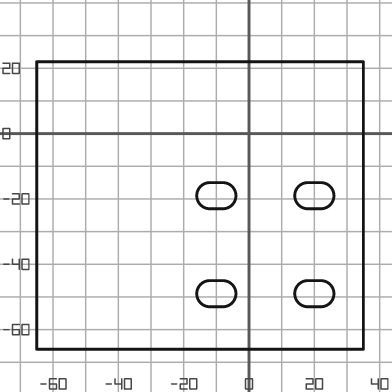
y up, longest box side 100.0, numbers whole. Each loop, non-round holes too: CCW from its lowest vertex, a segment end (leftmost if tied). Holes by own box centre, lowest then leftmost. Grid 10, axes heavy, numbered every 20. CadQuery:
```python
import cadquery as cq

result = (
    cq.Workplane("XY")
    .moveTo(-65.0, -66.0)
    .lineTo(35.0, -66.0)
    .lineTo(35.0, 22.0)
    .lineTo(-65.0, 22.0)
    .close()
    .moveTo(-12.0, -53.0)
    .lineTo(-8.0, -53.0)
    .threePointArc((-4.0, -49.0), (-8.0, -45.0))
    .lineTo(-12.0, -45.0)
    .threePointArc((-16.0, -49.0), (-12.0, -53.0))
    .close()
    .moveTo(18.0, -53.0)
    .lineTo(22.0, -53.0)
    .threePointArc((26.0, -49.0), (22.0, -45.0))
    .lineTo(18.0, -45.0)
    .threePointArc((14.0, -49.0), (18.0, -53.0))
    .close()
    .moveTo(-12.0, -23.0)
    .lineTo(-8.0, -23.0)
    .threePointArc((-4.0, -19.0), (-8.0, -15.0))
    .lineTo(-12.0, -15.0)
    .threePointArc((-16.0, -19.0), (-12.0, -23.0))
    .close()
    .moveTo(18.0, -23.0)
    .lineTo(22.0, -23.0)
    .threePointArc((26.0, -19.0), (22.0, -15.0))
    .lineTo(18.0, -15.0)
    .threePointArc((14.0, -19.0), (18.0, -23.0))
    .close()
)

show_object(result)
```